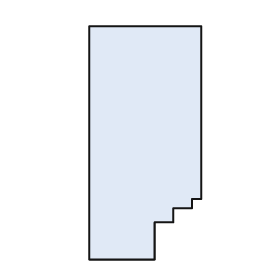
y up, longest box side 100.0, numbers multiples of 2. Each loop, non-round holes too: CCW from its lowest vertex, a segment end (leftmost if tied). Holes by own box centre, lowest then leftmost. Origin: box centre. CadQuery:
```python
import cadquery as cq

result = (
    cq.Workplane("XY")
    .moveTo(-24.0, -50.0)
    .lineTo(4.0, -50.0)
    .lineTo(4.0, -34.0)
    .lineTo(12.0, -34.0)
    .lineTo(12.0, -28.0)
    .lineTo(20.0, -28.0)
    .lineTo(20.0, -24.0)
    .lineTo(24.0, -24.0)
    .lineTo(24.0, 50.0)
    .lineTo(-24.0, 50.0)
    .close()
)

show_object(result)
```